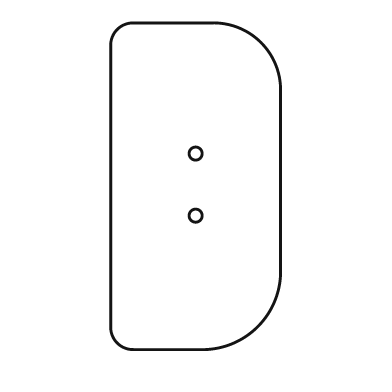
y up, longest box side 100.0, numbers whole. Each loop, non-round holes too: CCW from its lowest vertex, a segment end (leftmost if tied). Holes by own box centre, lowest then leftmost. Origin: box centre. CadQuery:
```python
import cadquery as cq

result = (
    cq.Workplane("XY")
    .moveTo(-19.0, -50.0)
    .lineTo(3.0, -50.0)
    .threePointArc((19.0, -43.0), (26.0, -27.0))
    .lineTo(26.0, 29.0)
    .threePointArc((20.0, 44.0), (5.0, 50.0))
    .lineTo(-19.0, 50.0)
    .threePointArc((-24.0, 48.0), (-26.0, 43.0))
    .lineTo(-26.0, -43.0)
    .threePointArc((-24.0, -48.0), (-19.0, -50.0))
    .close()
    .moveTo(0.0, -9.0)
    .circle(2.0)
    .moveTo(0.0, 10.0)
    .circle(2.0)
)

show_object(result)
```